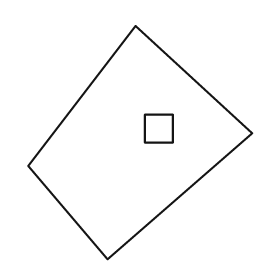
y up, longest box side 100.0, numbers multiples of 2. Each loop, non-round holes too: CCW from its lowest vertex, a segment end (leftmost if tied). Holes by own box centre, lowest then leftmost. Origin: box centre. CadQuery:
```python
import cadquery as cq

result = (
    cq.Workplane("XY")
    .moveTo(-14.0, -50.0)
    .lineTo(48.0, 4.0)
    .lineTo(-2.0, 50.0)
    .lineTo(-48.0, -10.0)
    .close()
    .moveTo(2.0, 0.0)
    .lineTo(14.0, 0.0)
    .lineTo(14.0, 12.0)
    .lineTo(2.0, 12.0)
    .close()
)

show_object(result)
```